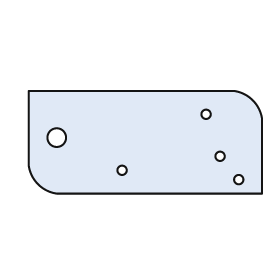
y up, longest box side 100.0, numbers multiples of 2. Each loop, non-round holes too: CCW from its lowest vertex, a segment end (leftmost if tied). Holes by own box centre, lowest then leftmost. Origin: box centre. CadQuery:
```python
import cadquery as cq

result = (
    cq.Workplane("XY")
    .moveTo(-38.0, -22.0)
    .lineTo(50.0, -22.0)
    .lineTo(50.0, 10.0)
    .threePointArc((46.0, 18.0), (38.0, 22.0))
    .lineTo(-50.0, 22.0)
    .lineTo(-50.0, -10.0)
    .threePointArc((-46.0, -18.0), (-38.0, -22.0))
    .close()
    .moveTo(40.0, -16.0)
    .circle(2.0)
    .moveTo(-10.0, -12.0)
    .circle(2.0)
    .moveTo(32.0, -6.0)
    .circle(2.0)
    .moveTo(-38.0, 2.0)
    .circle(4.0)
    .moveTo(26.0, 12.0)
    .circle(2.0)
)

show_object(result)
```